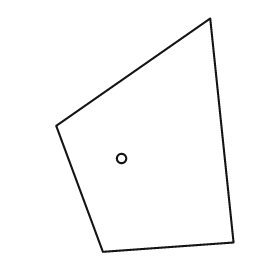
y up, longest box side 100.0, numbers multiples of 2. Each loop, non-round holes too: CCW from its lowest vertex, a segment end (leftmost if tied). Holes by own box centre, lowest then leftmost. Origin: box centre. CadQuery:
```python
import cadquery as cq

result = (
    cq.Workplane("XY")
    .moveTo(-18.0, -50.0)
    .lineTo(38.0, -46.0)
    .lineTo(28.0, 50.0)
    .lineTo(-38.0, 4.0)
    .close()
    .moveTo(-10.0, -10.0)
    .circle(2.0)
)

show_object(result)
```